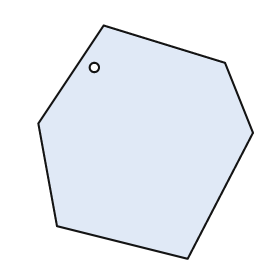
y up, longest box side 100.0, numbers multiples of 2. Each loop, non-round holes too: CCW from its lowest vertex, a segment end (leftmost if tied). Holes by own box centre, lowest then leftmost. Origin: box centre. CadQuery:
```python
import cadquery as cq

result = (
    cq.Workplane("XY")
    .moveTo(18.0, -50.0)
    .lineTo(46.0, 4.0)
    .lineTo(34.0, 34.0)
    .lineTo(-18.0, 50.0)
    .lineTo(-46.0, 8.0)
    .lineTo(-38.0, -36.0)
    .close()
    .moveTo(-22.0, 32.0)
    .circle(2.0)
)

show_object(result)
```